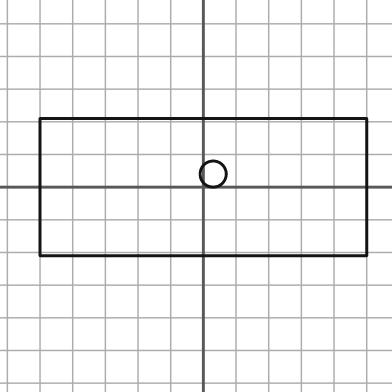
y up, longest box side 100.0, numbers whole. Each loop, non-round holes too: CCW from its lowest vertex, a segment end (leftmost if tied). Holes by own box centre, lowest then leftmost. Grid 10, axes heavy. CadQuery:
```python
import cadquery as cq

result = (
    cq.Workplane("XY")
    .moveTo(-50.0, -21.0)
    .lineTo(50.0, -21.0)
    .lineTo(50.0, 21.0)
    .lineTo(-50.0, 21.0)
    .close()
    .moveTo(3.0, 4.0)
    .circle(4.0)
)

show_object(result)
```